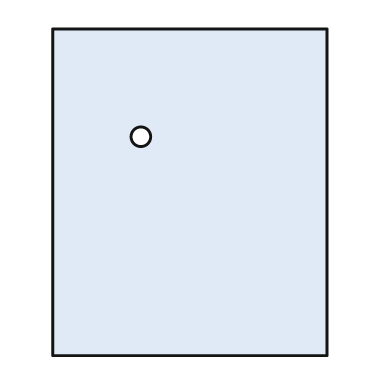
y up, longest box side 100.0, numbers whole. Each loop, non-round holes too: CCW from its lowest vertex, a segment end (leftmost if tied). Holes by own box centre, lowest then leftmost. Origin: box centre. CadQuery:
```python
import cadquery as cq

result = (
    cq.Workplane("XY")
    .moveTo(-42.0, -50.0)
    .lineTo(42.0, -50.0)
    .lineTo(42.0, 50.0)
    .lineTo(-42.0, 50.0)
    .close()
    .moveTo(-15.0, 17.0)
    .circle(3.0)
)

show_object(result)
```